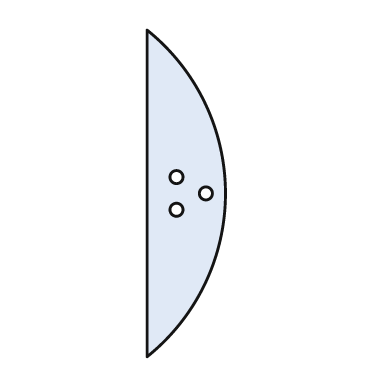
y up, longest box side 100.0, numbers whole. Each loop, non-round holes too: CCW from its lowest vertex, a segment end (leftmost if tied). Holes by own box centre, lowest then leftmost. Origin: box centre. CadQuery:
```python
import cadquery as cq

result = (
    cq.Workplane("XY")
    .moveTo(-12.0, -50.0)
    .threePointArc((12.0, 0.0), (-12.0, 50.0))
    .close()
    .moveTo(-3.0, -5.0)
    .circle(2.0)
    .moveTo(6.0, 0.0)
    .circle(2.0)
    .moveTo(-3.0, 5.0)
    .circle(2.0)
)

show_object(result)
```